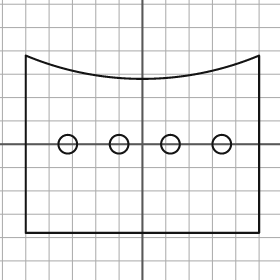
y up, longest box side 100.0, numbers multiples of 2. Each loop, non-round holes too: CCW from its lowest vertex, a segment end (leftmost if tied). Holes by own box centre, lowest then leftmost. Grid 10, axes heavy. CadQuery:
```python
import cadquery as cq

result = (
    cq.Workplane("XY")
    .moveTo(-50.0, -38.0)
    .lineTo(50.0, -38.0)
    .lineTo(50.0, 38.0)
    .threePointArc((0.0, 28.0), (-50.0, 38.0))
    .close()
    .moveTo(-32.0, 0.0)
    .circle(4.0)
    .moveTo(-10.0, 0.0)
    .circle(4.0)
    .moveTo(12.0, 0.0)
    .circle(4.0)
    .moveTo(34.0, 0.0)
    .circle(4.0)
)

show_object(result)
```